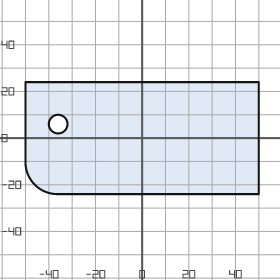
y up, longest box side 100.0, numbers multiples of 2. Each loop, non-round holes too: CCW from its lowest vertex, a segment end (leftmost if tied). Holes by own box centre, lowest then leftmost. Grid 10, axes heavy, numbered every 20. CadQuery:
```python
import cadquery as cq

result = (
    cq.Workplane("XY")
    .moveTo(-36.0, -24.0)
    .lineTo(50.0, -24.0)
    .lineTo(50.0, 24.0)
    .lineTo(-50.0, 24.0)
    .lineTo(-50.0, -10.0)
    .threePointArc((-46.0, -20.0), (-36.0, -24.0))
    .close()
    .moveTo(-36.0, 6.0)
    .circle(4.0)
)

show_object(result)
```